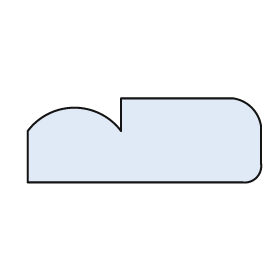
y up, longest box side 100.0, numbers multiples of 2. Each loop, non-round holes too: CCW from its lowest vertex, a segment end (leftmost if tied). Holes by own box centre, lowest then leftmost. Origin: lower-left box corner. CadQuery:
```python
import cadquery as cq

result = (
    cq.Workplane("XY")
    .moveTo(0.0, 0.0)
    .lineTo(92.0, 0.0)
    .threePointArc((98.0, 2.0), (100.0, 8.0))
    .lineTo(100.0, 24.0)
    .threePointArc((96.0, 32.0), (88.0, 36.0))
    .lineTo(40.0, 36.0)
    .lineTo(40.0, 22.0)
    .threePointArc((20.0, 32.0), (0.0, 22.0))
    .close()
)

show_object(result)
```